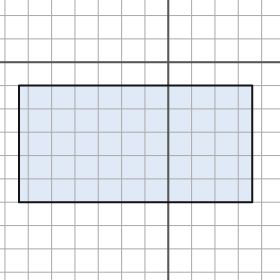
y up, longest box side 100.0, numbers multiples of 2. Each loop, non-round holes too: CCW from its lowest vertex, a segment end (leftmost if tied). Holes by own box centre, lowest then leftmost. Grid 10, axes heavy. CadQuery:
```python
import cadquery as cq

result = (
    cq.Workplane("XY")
    .moveTo(-64.0, -60.0)
    .lineTo(36.0, -60.0)
    .lineTo(36.0, -10.0)
    .lineTo(-64.0, -10.0)
    .close()
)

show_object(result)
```